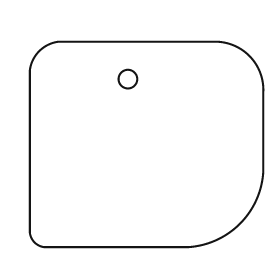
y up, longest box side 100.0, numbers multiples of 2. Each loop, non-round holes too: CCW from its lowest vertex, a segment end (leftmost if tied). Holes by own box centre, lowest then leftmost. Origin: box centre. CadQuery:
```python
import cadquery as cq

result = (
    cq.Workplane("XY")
    .moveTo(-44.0, -44.0)
    .lineTo(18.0, -44.0)
    .threePointArc((40.0, -34.0), (50.0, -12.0))
    .lineTo(50.0, 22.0)
    .threePointArc((44.0, 38.0), (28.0, 44.0))
    .lineTo(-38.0, 44.0)
    .threePointArc((-46.0, 40.0), (-50.0, 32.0))
    .lineTo(-50.0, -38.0)
    .threePointArc((-48.0, -42.0), (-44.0, -44.0))
    .close()
    .moveTo(-8.0, 28.0)
    .circle(4.0)
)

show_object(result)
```